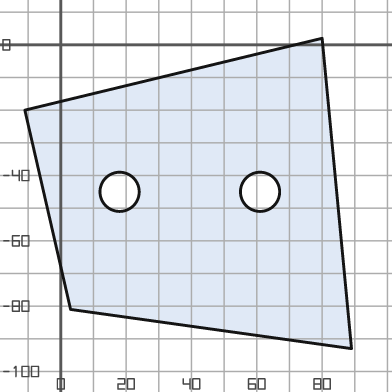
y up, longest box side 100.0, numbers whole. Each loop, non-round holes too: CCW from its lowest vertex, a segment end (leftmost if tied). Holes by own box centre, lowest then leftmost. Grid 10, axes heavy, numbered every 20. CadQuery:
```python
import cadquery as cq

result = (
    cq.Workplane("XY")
    .moveTo(89.0, -93.0)
    .lineTo(80.0, 2.0)
    .lineTo(-11.0, -20.0)
    .lineTo(3.0, -81.0)
    .close()
    .moveTo(18.0, -45.0)
    .circle(6.0)
    .moveTo(61.0, -45.0)
    .circle(6.0)
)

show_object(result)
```